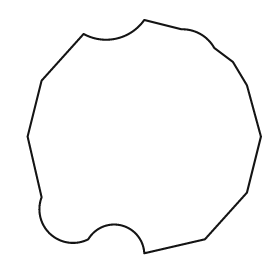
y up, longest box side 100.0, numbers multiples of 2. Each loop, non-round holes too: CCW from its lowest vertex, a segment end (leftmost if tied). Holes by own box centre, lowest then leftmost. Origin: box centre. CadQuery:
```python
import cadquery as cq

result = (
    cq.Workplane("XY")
    .moveTo(0.0, -50.0)
    .lineTo(26.0, -44.0)
    .lineTo(44.0, -24.0)
    .lineTo(50.0, 0.0)
    .lineTo(44.0, 22.0)
    .lineTo(38.0, 32.0)
    .lineTo(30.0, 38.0)
    .threePointArc((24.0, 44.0), (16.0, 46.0))
    .lineTo(0.0, 50.0)
    .threePointArc((-12.0, 42.0), (-26.0, 44.0))
    .lineTo(-44.0, 24.0)
    .lineTo(-50.0, 0.0)
    .lineTo(-44.0, -26.0)
    .threePointArc((-40.0, -42.0), (-24.0, -44.0))
    .threePointArc((-10.0, -38.0), (0.0, -50.0))
    .close()
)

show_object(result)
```